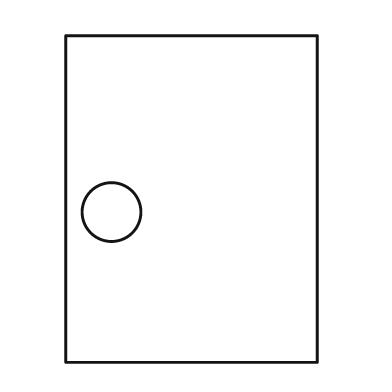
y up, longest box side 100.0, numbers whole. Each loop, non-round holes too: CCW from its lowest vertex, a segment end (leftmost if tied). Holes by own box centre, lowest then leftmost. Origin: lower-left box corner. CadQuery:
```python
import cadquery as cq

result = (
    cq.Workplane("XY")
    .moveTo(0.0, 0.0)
    .lineTo(77.0, 0.0)
    .lineTo(77.0, 100.0)
    .lineTo(0.0, 100.0)
    .close()
    .moveTo(14.0, 46.0)
    .circle(9.0)
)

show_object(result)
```